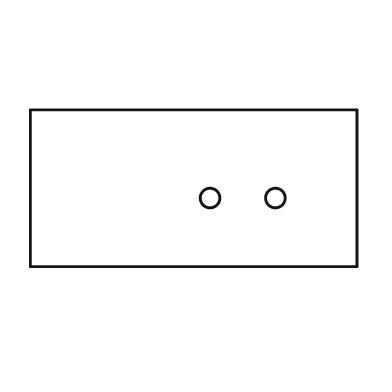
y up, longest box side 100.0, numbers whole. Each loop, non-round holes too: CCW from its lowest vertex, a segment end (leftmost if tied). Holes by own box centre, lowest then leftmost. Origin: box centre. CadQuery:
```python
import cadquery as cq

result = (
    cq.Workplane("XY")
    .moveTo(-50.0, -24.0)
    .lineTo(50.0, -24.0)
    .lineTo(50.0, 24.0)
    .lineTo(-50.0, 24.0)
    .close()
    .moveTo(5.0, -3.0)
    .circle(3.0)
    .moveTo(25.0, -3.0)
    .circle(3.0)
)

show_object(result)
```